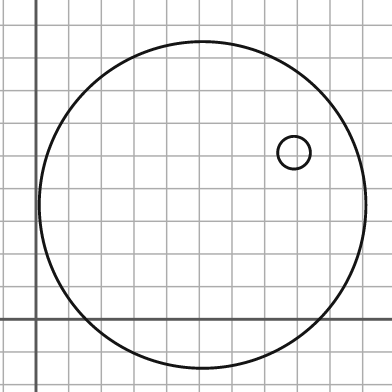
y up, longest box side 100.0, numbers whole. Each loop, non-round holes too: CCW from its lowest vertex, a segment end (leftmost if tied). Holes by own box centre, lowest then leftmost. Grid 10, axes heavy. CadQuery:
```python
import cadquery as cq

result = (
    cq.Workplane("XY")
    .moveTo(51.0, 35.0)
    .circle(50.0)
    .moveTo(79.0, 51.0)
    .circle(5.0)
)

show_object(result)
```